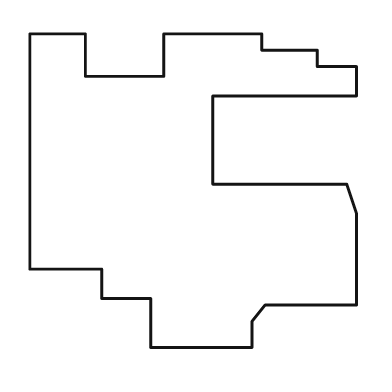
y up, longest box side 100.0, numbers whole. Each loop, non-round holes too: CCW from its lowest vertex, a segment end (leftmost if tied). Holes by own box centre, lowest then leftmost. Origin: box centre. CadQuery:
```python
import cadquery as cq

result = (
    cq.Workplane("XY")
    .moveTo(-13.0, -48.0)
    .lineTo(18.0, -48.0)
    .lineTo(18.0, -40.0)
    .lineTo(22.0, -35.0)
    .lineTo(50.0, -35.0)
    .lineTo(50.0, -7.0)
    .lineTo(47.0, 2.0)
    .lineTo(6.0, 2.0)
    .lineTo(6.0, 29.0)
    .lineTo(50.0, 29.0)
    .lineTo(50.0, 38.0)
    .lineTo(38.0, 38.0)
    .lineTo(38.0, 43.0)
    .lineTo(21.0, 43.0)
    .lineTo(21.0, 48.0)
    .lineTo(-9.0, 48.0)
    .lineTo(-9.0, 35.0)
    .lineTo(-33.0, 35.0)
    .lineTo(-33.0, 48.0)
    .lineTo(-50.0, 48.0)
    .lineTo(-50.0, -24.0)
    .lineTo(-28.0, -24.0)
    .lineTo(-28.0, -33.0)
    .lineTo(-13.0, -33.0)
    .close()
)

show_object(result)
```